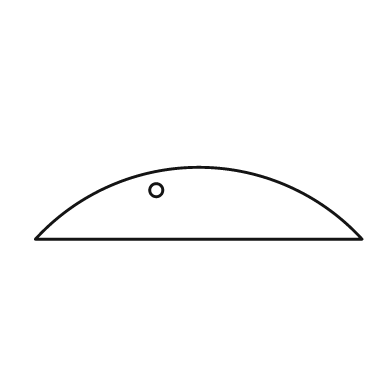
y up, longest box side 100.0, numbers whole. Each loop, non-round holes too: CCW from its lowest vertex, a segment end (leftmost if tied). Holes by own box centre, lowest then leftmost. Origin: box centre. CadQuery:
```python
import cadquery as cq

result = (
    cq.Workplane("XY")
    .moveTo(-50.0, -11.0)
    .lineTo(50.0, -11.0)
    .threePointArc((0.0, 11.0), (-50.0, -11.0))
    .close()
    .moveTo(-13.0, 4.0)
    .circle(2.0)
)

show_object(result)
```